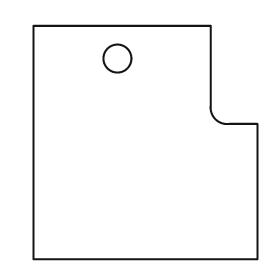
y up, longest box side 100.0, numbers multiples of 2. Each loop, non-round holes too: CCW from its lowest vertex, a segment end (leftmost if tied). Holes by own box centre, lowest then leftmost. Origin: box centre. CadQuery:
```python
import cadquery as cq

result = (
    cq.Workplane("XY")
    .moveTo(-48.0, -50.0)
    .lineTo(48.0, -50.0)
    .lineTo(48.0, 8.0)
    .lineTo(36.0, 8.0)
    .threePointArc((30.0, 10.0), (28.0, 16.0))
    .lineTo(28.0, 50.0)
    .lineTo(-48.0, 50.0)
    .close()
    .moveTo(-12.0, 36.0)
    .circle(6.0)
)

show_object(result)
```